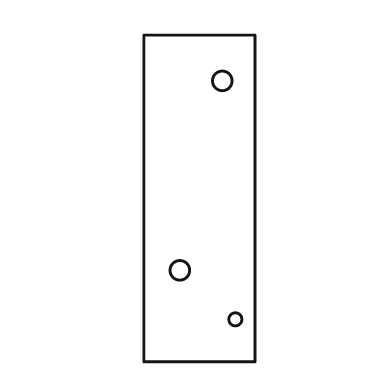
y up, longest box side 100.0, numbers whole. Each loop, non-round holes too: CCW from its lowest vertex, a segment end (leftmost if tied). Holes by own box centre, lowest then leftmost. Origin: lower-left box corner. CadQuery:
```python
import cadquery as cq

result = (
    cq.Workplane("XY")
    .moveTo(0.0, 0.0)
    .lineTo(34.0, 0.0)
    .lineTo(34.0, 100.0)
    .lineTo(0.0, 100.0)
    .close()
    .moveTo(28.0, 13.0)
    .circle(2.0)
    .moveTo(11.0, 28.0)
    .circle(3.0)
    .moveTo(24.0, 86.0)
    .circle(3.0)
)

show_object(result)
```